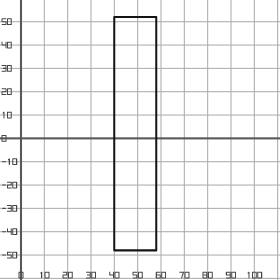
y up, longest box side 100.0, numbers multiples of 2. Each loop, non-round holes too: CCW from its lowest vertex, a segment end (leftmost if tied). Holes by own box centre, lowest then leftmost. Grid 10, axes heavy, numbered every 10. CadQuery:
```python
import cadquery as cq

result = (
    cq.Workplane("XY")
    .moveTo(40.0, -48.0)
    .lineTo(58.0, -48.0)
    .lineTo(58.0, 52.0)
    .lineTo(40.0, 52.0)
    .close()
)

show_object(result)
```